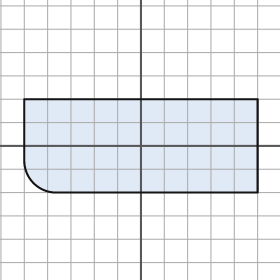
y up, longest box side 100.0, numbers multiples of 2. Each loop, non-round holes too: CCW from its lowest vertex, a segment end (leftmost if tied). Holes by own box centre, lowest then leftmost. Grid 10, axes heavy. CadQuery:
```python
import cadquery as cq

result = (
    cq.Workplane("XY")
    .moveTo(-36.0, -20.0)
    .lineTo(50.0, -20.0)
    .lineTo(50.0, 20.0)
    .lineTo(-50.0, 20.0)
    .lineTo(-50.0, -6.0)
    .threePointArc((-46.0, -16.0), (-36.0, -20.0))
    .close()
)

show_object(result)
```